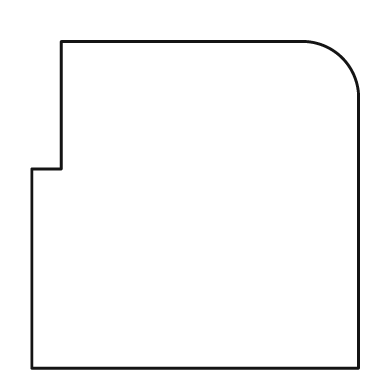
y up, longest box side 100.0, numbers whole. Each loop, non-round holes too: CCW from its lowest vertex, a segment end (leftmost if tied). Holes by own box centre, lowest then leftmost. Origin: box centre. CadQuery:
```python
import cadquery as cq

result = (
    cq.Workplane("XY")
    .moveTo(-50.0, -50.0)
    .lineTo(50.0, -50.0)
    .lineTo(50.0, 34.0)
    .threePointArc((45.0, 45.0), (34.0, 50.0))
    .lineTo(-41.0, 50.0)
    .lineTo(-41.0, 11.0)
    .lineTo(-50.0, 11.0)
    .close()
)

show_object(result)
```